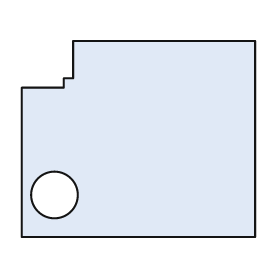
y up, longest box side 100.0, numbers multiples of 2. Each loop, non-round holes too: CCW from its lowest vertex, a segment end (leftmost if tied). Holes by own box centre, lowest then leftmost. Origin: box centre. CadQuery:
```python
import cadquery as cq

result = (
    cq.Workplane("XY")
    .moveTo(-50.0, -42.0)
    .lineTo(50.0, -42.0)
    .lineTo(50.0, 42.0)
    .lineTo(-28.0, 42.0)
    .lineTo(-28.0, 26.0)
    .lineTo(-32.0, 26.0)
    .lineTo(-32.0, 22.0)
    .lineTo(-50.0, 22.0)
    .close()
    .moveTo(-36.0, -24.0)
    .circle(10.0)
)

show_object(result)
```